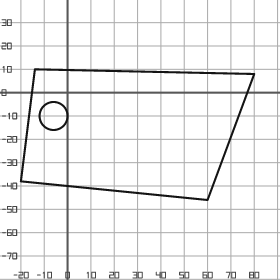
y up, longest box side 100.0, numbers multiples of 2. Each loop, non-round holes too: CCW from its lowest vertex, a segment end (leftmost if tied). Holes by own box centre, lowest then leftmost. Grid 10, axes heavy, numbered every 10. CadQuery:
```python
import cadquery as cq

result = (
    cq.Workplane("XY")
    .moveTo(60.0, -46.0)
    .lineTo(80.0, 8.0)
    .lineTo(-14.0, 10.0)
    .lineTo(-20.0, -38.0)
    .close()
    .moveTo(-6.0, -10.0)
    .circle(6.0)
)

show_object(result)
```